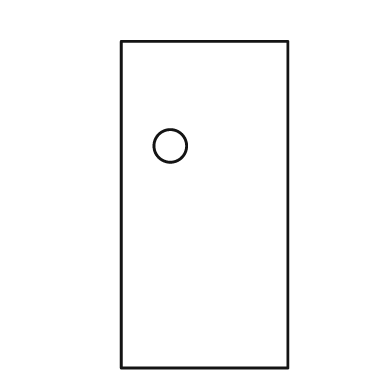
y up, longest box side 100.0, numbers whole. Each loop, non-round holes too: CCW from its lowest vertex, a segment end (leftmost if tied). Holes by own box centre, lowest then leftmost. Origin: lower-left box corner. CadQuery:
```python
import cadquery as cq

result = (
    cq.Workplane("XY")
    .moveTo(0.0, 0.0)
    .lineTo(51.0, 0.0)
    .lineTo(51.0, 100.0)
    .lineTo(0.0, 100.0)
    .close()
    .moveTo(15.0, 68.0)
    .circle(5.0)
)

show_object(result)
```